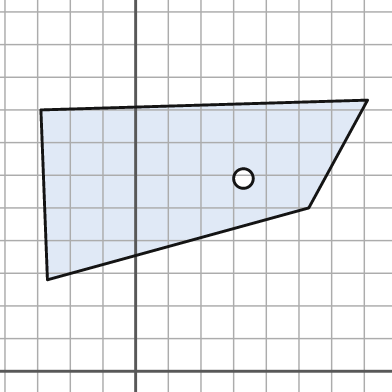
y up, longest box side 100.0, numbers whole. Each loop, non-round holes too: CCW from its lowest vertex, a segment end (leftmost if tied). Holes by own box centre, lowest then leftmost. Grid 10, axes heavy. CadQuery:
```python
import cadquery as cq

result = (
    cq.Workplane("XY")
    .moveTo(-27.0, 28.0)
    .lineTo(53.0, 50.0)
    .lineTo(71.0, 83.0)
    .lineTo(-29.0, 80.0)
    .close()
    .moveTo(33.0, 59.0)
    .circle(3.0)
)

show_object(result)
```